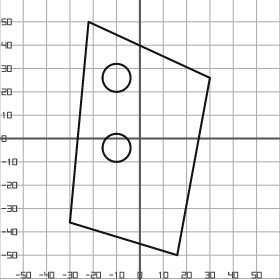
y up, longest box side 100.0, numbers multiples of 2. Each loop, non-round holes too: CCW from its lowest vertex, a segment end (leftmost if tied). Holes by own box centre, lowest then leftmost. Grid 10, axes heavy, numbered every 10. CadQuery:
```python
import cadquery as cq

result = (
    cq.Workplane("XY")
    .moveTo(16.0, -50.0)
    .lineTo(30.0, 26.0)
    .lineTo(-22.0, 50.0)
    .lineTo(-30.0, -36.0)
    .close()
    .moveTo(-10.0, -4.0)
    .circle(6.0)
    .moveTo(-10.0, 26.0)
    .circle(6.0)
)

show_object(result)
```